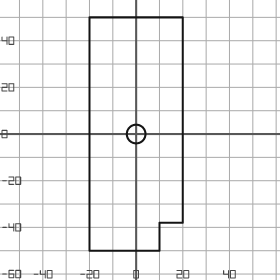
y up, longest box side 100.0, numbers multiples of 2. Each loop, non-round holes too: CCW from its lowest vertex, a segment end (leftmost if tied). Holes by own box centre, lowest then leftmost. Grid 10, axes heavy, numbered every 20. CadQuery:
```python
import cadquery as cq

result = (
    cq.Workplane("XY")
    .moveTo(-20.0, -50.0)
    .lineTo(10.0, -50.0)
    .lineTo(10.0, -38.0)
    .lineTo(20.0, -38.0)
    .lineTo(20.0, 50.0)
    .lineTo(-20.0, 50.0)
    .close()
    .moveTo(0.0, 0.0)
    .circle(4.0)
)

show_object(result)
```